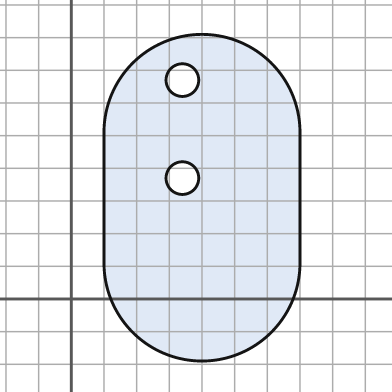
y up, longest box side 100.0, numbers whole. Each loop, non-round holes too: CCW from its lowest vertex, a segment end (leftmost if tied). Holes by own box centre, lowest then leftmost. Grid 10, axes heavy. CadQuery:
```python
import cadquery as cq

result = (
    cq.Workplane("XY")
    .moveTo(10.0, 11.0)
    .threePointArc((40.0, -19.0), (70.0, 11.0))
    .lineTo(70.0, 51.0)
    .threePointArc((40.0, 81.0), (10.0, 51.0))
    .close()
    .moveTo(34.0, 37.0)
    .circle(5.0)
    .moveTo(34.0, 67.0)
    .circle(5.0)
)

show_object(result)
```